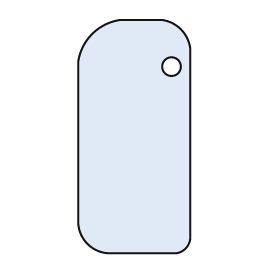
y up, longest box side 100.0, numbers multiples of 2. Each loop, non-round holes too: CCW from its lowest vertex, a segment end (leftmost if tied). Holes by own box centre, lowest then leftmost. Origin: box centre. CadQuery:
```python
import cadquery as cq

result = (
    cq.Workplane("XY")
    .moveTo(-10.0, -50.0)
    .lineTo(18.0, -50.0)
    .threePointArc((22.0, -48.0), (24.0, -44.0))
    .lineTo(24.0, 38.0)
    .threePointArc((20.0, 46.0), (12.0, 50.0))
    .lineTo(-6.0, 50.0)
    .threePointArc((-18.0, 44.0), (-24.0, 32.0))
    .lineTo(-24.0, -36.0)
    .threePointArc((-20.0, -46.0), (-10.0, -50.0))
    .close()
    .moveTo(16.0, 30.0)
    .circle(4.0)
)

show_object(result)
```